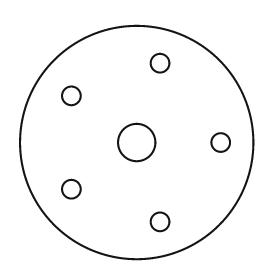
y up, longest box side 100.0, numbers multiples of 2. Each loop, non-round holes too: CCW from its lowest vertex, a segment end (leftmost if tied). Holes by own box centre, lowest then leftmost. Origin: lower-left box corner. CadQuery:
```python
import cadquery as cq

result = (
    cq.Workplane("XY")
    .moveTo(50.0, 50.0)
    .circle(50.0)
    .moveTo(60.0, 16.0)
    .circle(4.0)
    .moveTo(22.0, 30.0)
    .circle(4.0)
    .moveTo(50.0, 50.0)
    .circle(8.0)
    .moveTo(86.0, 50.0)
    .circle(4.0)
    .moveTo(22.0, 70.0)
    .circle(4.0)
    .moveTo(60.0, 84.0)
    .circle(4.0)
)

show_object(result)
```